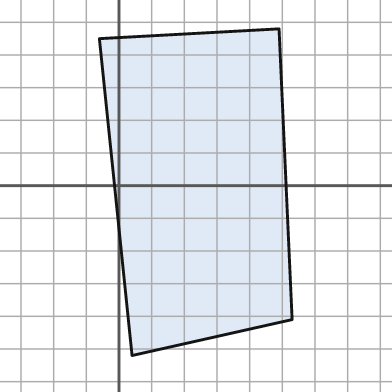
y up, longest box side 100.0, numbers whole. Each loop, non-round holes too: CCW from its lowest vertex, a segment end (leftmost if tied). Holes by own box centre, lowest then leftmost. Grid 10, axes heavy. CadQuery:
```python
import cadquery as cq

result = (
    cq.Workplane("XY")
    .moveTo(4.0, -52.0)
    .lineTo(53.0, -41.0)
    .lineTo(49.0, 48.0)
    .lineTo(-6.0, 45.0)
    .close()
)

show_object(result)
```